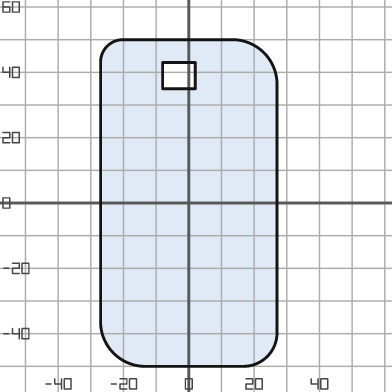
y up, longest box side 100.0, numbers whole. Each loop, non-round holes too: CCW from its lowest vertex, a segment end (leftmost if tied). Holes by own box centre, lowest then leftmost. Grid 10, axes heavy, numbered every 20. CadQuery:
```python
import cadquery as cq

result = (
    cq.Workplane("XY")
    .moveTo(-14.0, -50.0)
    .lineTo(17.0, -50.0)
    .threePointArc((24.0, -47.0), (27.0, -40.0))
    .lineTo(27.0, 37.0)
    .threePointArc((23.0, 46.0), (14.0, 50.0))
    .lineTo(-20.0, 50.0)
    .threePointArc((-25.0, 48.0), (-27.0, 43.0))
    .lineTo(-27.0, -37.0)
    .threePointArc((-23.0, -46.0), (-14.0, -50.0))
    .close()
    .moveTo(-8.0, 35.0)
    .lineTo(2.0, 35.0)
    .lineTo(2.0, 43.0)
    .lineTo(-8.0, 43.0)
    .close()
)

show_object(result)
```